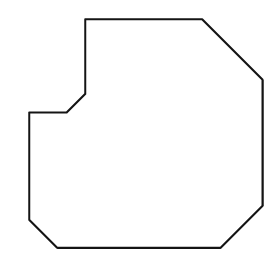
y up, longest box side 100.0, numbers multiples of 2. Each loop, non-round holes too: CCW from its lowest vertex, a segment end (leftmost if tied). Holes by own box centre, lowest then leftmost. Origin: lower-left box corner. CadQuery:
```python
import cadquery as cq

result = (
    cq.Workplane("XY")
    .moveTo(12.0, 0.0)
    .lineTo(82.0, 0.0)
    .lineTo(100.0, 18.0)
    .lineTo(100.0, 72.0)
    .lineTo(74.0, 98.0)
    .lineTo(24.0, 98.0)
    .lineTo(24.0, 66.0)
    .lineTo(16.0, 58.0)
    .lineTo(0.0, 58.0)
    .lineTo(0.0, 12.0)
    .close()
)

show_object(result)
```